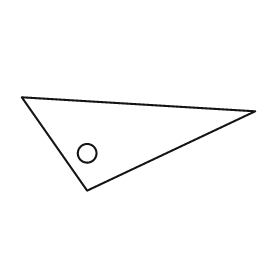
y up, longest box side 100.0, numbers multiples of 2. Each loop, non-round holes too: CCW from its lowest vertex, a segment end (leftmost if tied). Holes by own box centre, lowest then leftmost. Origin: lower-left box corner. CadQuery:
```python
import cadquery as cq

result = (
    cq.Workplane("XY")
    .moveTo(28.0, 0.0)
    .lineTo(100.0, 34.0)
    .lineTo(0.0, 40.0)
    .close()
    .moveTo(28.0, 16.0)
    .circle(4.0)
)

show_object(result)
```